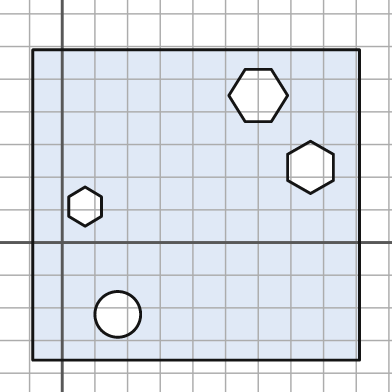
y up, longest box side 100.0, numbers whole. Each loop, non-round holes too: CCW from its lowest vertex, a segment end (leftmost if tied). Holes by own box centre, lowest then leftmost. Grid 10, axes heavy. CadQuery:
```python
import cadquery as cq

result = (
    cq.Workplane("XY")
    .moveTo(-9.0, -36.0)
    .lineTo(91.0, -36.0)
    .lineTo(91.0, 59.0)
    .lineTo(-9.0, 59.0)
    .close()
    .moveTo(17.0, -22.0)
    .circle(7.0)
    .moveTo(7.0, 5.0)
    .lineTo(12.0, 8.0)
    .lineTo(12.0, 14.0)
    .lineTo(7.0, 17.0)
    .lineTo(2.0, 14.0)
    .lineTo(2.0, 8.0)
    .close()
    .moveTo(76.0, 15.0)
    .lineTo(83.0, 19.0)
    .lineTo(83.0, 27.0)
    .lineTo(76.0, 31.0)
    .lineTo(69.0, 27.0)
    .lineTo(69.0, 19.0)
    .close()
    .moveTo(56.0, 37.0)
    .lineTo(64.0, 37.0)
    .lineTo(69.0, 45.0)
    .lineTo(64.0, 53.0)
    .lineTo(56.0, 53.0)
    .lineTo(51.0, 45.0)
    .close()
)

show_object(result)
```